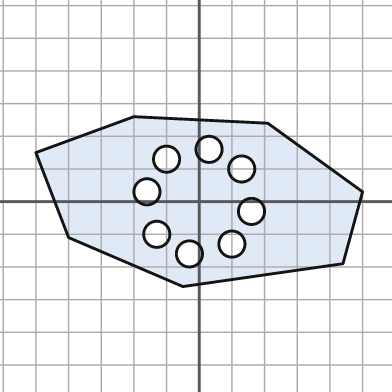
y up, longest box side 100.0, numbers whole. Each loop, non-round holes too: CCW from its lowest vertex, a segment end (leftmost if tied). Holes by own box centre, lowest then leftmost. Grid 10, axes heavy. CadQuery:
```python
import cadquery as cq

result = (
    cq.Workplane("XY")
    .moveTo(-5.0, -26.0)
    .lineTo(44.0, -19.0)
    .lineTo(50.0, 3.0)
    .lineTo(21.0, 24.0)
    .lineTo(-20.0, 26.0)
    .lineTo(-50.0, 15.0)
    .lineTo(-40.0, -11.0)
    .close()
    .moveTo(-3.0, -16.0)
    .circle(4.0)
    .moveTo(10.0, -13.0)
    .circle(4.0)
    .moveTo(-13.0, -10.0)
    .circle(4.0)
    .moveTo(16.0, -3.0)
    .circle(4.0)
    .moveTo(-16.0, 3.0)
    .circle(4.0)
    .moveTo(13.0, 10.0)
    .circle(4.0)
    .moveTo(-10.0, 13.0)
    .circle(4.0)
    .moveTo(3.0, 16.0)
    .circle(4.0)
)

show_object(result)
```